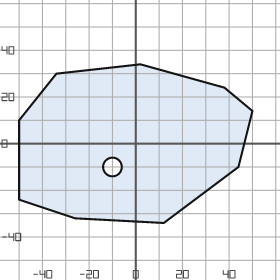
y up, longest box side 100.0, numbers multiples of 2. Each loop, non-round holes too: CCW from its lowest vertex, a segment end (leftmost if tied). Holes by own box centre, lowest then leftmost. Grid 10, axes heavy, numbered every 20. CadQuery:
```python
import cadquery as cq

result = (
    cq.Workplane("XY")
    .moveTo(12.0, -34.0)
    .lineTo(44.0, -10.0)
    .lineTo(50.0, 14.0)
    .lineTo(38.0, 24.0)
    .lineTo(2.0, 34.0)
    .lineTo(-34.0, 30.0)
    .lineTo(-50.0, 10.0)
    .lineTo(-50.0, -24.0)
    .lineTo(-26.0, -32.0)
    .close()
    .moveTo(-10.0, -10.0)
    .circle(4.0)
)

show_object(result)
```